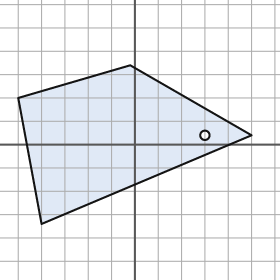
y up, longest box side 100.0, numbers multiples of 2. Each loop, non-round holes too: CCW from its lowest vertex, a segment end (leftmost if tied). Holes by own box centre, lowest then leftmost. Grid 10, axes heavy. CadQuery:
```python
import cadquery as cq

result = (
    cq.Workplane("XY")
    .moveTo(-40.0, -34.0)
    .lineTo(50.0, 4.0)
    .lineTo(-2.0, 34.0)
    .lineTo(-50.0, 20.0)
    .close()
    .moveTo(30.0, 4.0)
    .circle(2.0)
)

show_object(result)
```